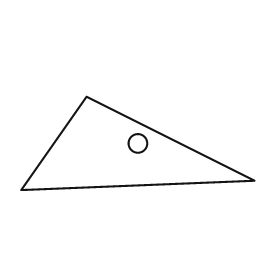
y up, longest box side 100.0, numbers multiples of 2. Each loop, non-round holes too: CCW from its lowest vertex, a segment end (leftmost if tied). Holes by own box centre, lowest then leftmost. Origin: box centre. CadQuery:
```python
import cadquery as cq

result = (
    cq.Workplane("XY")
    .moveTo(-50.0, -20.0)
    .lineTo(50.0, -16.0)
    .lineTo(-22.0, 20.0)
    .close()
    .moveTo(0.0, 0.0)
    .circle(4.0)
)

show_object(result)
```